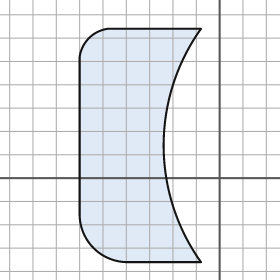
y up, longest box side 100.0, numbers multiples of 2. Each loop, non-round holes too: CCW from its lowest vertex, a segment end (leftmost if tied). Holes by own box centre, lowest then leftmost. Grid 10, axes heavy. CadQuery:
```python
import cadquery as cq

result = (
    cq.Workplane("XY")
    .moveTo(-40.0, -36.0)
    .lineTo(-8.0, -36.0)
    .threePointArc((-24.0, 14.0), (-8.0, 64.0))
    .lineTo(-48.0, 64.0)
    .threePointArc((-56.0, 60.0), (-60.0, 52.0))
    .lineTo(-60.0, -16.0)
    .threePointArc((-54.0, -30.0), (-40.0, -36.0))
    .close()
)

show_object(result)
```